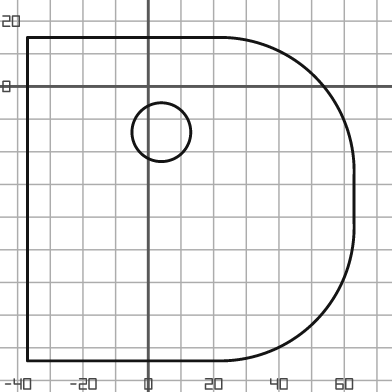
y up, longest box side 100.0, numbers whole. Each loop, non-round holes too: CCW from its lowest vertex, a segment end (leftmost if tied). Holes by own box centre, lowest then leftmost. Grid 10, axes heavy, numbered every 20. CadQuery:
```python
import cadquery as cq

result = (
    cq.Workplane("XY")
    .moveTo(-37.0, -84.0)
    .lineTo(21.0, -84.0)
    .threePointArc((51.0, -72.0), (63.0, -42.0))
    .lineTo(63.0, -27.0)
    .threePointArc((51.0, 3.0), (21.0, 15.0))
    .lineTo(-37.0, 15.0)
    .close()
    .moveTo(4.0, -14.0)
    .circle(9.0)
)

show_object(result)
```